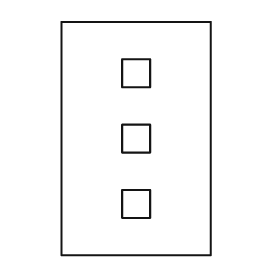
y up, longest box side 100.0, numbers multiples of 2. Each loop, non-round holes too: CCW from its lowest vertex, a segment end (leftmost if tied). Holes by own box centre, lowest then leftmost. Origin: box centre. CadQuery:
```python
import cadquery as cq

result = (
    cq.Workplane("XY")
    .moveTo(-32.0, -50.0)
    .lineTo(32.0, -50.0)
    .lineTo(32.0, 50.0)
    .lineTo(-32.0, 50.0)
    .close()
    .moveTo(-6.0, -34.0)
    .lineTo(6.0, -34.0)
    .lineTo(6.0, -22.0)
    .lineTo(-6.0, -22.0)
    .close()
    .moveTo(-6.0, -6.0)
    .lineTo(6.0, -6.0)
    .lineTo(6.0, 6.0)
    .lineTo(-6.0, 6.0)
    .close()
    .moveTo(-6.0, 22.0)
    .lineTo(6.0, 22.0)
    .lineTo(6.0, 34.0)
    .lineTo(-6.0, 34.0)
    .close()
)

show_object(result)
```